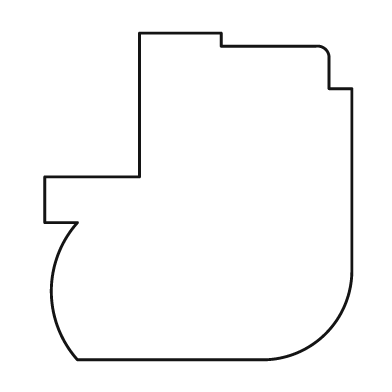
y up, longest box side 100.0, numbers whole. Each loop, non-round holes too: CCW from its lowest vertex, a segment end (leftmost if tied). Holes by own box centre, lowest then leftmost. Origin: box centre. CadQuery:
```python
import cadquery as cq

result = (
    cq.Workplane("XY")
    .moveTo(-37.0, -50.0)
    .lineTo(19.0, -50.0)
    .threePointArc((39.0, -42.0), (47.0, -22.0))
    .lineTo(47.0, 33.0)
    .lineTo(40.0, 33.0)
    .lineTo(40.0, 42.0)
    .threePointArc((39.0, 45.0), (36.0, 46.0))
    .lineTo(7.0, 46.0)
    .lineTo(7.0, 50.0)
    .lineTo(-18.0, 50.0)
    .lineTo(-18.0, 6.0)
    .lineTo(-47.0, 6.0)
    .lineTo(-47.0, -8.0)
    .lineTo(-37.0, -8.0)
    .threePointArc((-45.0, -29.0), (-37.0, -50.0))
    .close()
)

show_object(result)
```